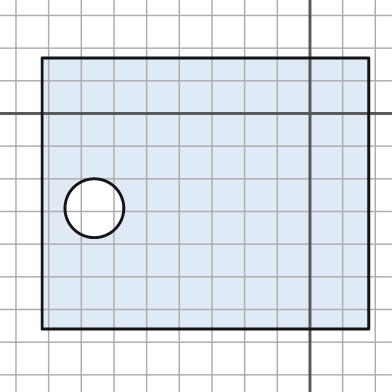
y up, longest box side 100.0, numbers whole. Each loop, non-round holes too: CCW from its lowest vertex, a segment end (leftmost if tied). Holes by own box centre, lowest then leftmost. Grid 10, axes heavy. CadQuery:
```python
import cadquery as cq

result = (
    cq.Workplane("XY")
    .moveTo(-82.0, -66.0)
    .lineTo(18.0, -66.0)
    .lineTo(18.0, 17.0)
    .lineTo(-82.0, 17.0)
    .close()
    .moveTo(-66.0, -29.0)
    .circle(9.0)
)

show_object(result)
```